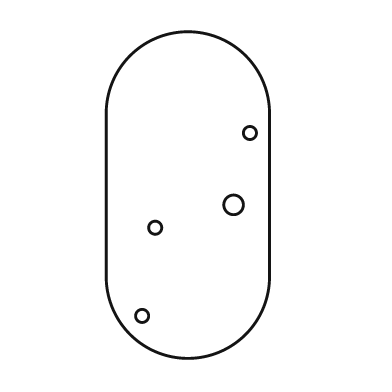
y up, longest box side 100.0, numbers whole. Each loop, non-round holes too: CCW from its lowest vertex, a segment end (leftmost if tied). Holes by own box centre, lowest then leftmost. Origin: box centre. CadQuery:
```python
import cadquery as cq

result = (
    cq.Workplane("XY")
    .moveTo(-25.0, -25.0)
    .threePointArc((0.0, -50.0), (25.0, -25.0))
    .lineTo(25.0, 25.0)
    .threePointArc((0.0, 50.0), (-25.0, 25.0))
    .close()
    .moveTo(-14.0, -37.0)
    .circle(2.0)
    .moveTo(-10.0, -10.0)
    .circle(2.0)
    .moveTo(14.0, -3.0)
    .circle(3.0)
    .moveTo(19.0, 19.0)
    .circle(2.0)
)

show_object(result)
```